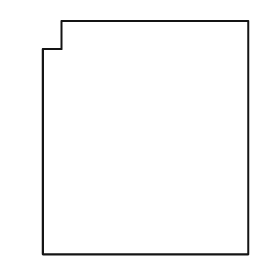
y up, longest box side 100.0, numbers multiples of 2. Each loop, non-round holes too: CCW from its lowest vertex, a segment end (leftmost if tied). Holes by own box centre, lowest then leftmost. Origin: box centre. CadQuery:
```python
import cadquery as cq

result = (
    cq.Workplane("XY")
    .moveTo(-44.0, -50.0)
    .lineTo(44.0, -50.0)
    .lineTo(44.0, 50.0)
    .lineTo(-36.0, 50.0)
    .lineTo(-36.0, 38.0)
    .lineTo(-44.0, 38.0)
    .close()
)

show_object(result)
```